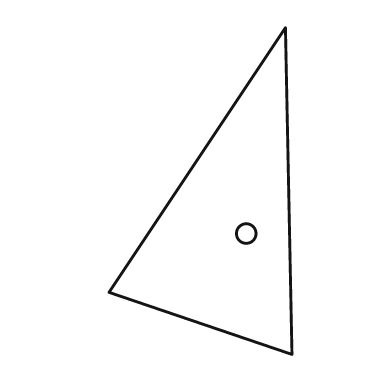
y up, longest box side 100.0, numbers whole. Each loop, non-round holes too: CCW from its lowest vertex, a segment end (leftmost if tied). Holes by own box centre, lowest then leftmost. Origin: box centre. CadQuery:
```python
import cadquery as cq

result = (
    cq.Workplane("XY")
    .moveTo(28.0, -50.0)
    .lineTo(26.0, 50.0)
    .lineTo(-28.0, -31.0)
    .close()
    .moveTo(14.0, -13.0)
    .circle(3.0)
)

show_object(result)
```